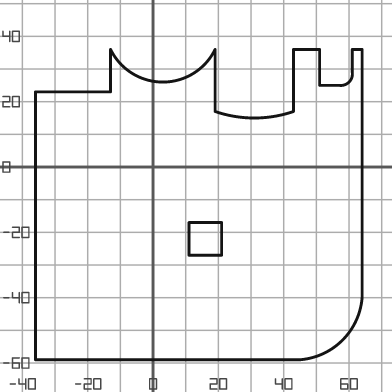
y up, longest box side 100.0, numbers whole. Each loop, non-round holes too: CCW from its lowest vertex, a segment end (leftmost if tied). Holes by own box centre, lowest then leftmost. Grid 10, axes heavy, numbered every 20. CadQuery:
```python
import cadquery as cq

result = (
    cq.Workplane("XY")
    .moveTo(-36.0, -59.0)
    .lineTo(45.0, -59.0)
    .threePointArc((58.0, -53.0), (64.0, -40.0))
    .lineTo(64.0, 36.0)
    .lineTo(61.0, 36.0)
    .lineTo(61.0, 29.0)
    .threePointArc((60.0, 26.0), (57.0, 25.0))
    .lineTo(51.0, 25.0)
    .lineTo(51.0, 36.0)
    .lineTo(43.0, 36.0)
    .lineTo(43.0, 17.0)
    .threePointArc((31.0, 15.0), (19.0, 17.0))
    .lineTo(19.0, 36.0)
    .threePointArc((3.0, 26.0), (-13.0, 36.0))
    .lineTo(-13.0, 23.0)
    .lineTo(-36.0, 23.0)
    .close()
    .moveTo(11.0, -27.0)
    .lineTo(21.0, -27.0)
    .lineTo(21.0, -17.0)
    .lineTo(11.0, -17.0)
    .close()
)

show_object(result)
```